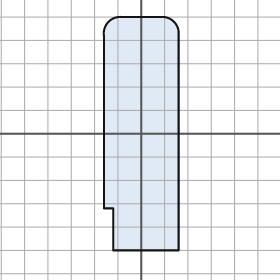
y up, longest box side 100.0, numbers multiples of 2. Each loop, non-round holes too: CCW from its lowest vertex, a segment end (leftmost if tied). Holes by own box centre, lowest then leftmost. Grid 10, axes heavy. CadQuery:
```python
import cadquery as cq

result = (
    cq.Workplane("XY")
    .moveTo(-12.0, -50.0)
    .lineTo(16.0, -50.0)
    .lineTo(16.0, 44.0)
    .threePointArc((14.0, 48.0), (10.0, 50.0))
    .lineTo(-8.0, 50.0)
    .threePointArc((-14.0, 48.0), (-16.0, 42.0))
    .lineTo(-16.0, -32.0)
    .lineTo(-12.0, -32.0)
    .close()
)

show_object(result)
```